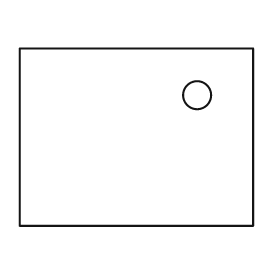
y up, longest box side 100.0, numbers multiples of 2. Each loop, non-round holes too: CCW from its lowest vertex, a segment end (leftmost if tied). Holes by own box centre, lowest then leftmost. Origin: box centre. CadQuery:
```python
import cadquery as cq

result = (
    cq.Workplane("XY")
    .moveTo(-50.0, -38.0)
    .lineTo(50.0, -38.0)
    .lineTo(50.0, 38.0)
    .lineTo(-50.0, 38.0)
    .close()
    .moveTo(26.0, 18.0)
    .circle(6.0)
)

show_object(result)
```